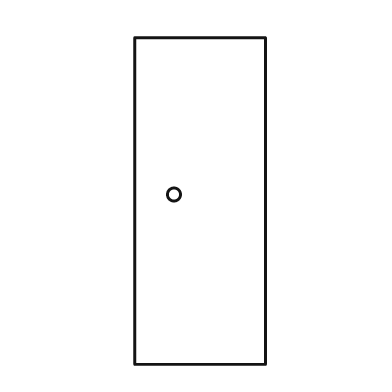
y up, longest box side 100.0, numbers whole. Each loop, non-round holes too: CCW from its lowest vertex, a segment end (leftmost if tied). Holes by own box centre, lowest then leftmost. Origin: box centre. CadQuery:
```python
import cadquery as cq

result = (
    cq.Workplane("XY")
    .moveTo(-20.0, -50.0)
    .lineTo(20.0, -50.0)
    .lineTo(20.0, 50.0)
    .lineTo(-20.0, 50.0)
    .close()
    .moveTo(-8.0, 2.0)
    .circle(2.0)
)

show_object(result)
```